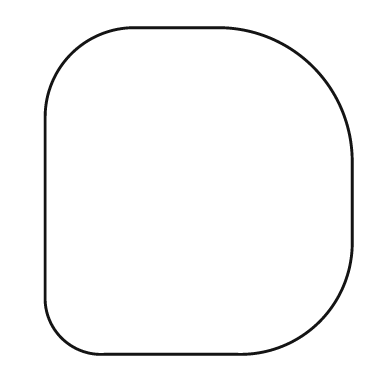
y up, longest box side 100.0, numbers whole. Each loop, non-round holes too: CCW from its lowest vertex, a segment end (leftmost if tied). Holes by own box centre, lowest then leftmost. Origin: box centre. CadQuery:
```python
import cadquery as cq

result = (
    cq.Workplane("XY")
    .moveTo(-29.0, -50.0)
    .lineTo(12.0, -50.0)
    .threePointArc((37.0, -40.0), (47.0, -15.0))
    .lineTo(47.0, 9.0)
    .threePointArc((35.0, 38.0), (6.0, 50.0))
    .lineTo(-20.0, 50.0)
    .threePointArc((-39.0, 42.0), (-47.0, 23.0))
    .lineTo(-47.0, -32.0)
    .threePointArc((-42.0, -45.0), (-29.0, -50.0))
    .close()
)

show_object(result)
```